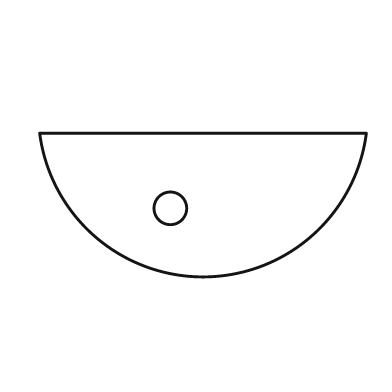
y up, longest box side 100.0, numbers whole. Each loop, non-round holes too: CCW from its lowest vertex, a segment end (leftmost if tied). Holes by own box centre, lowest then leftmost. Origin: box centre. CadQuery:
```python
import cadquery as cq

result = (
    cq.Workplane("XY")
    .moveTo(-50.0, 22.0)
    .threePointArc((0.0, -22.0), (50.0, 22.0))
    .close()
    .moveTo(-10.0, -1.0)
    .circle(5.0)
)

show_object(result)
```